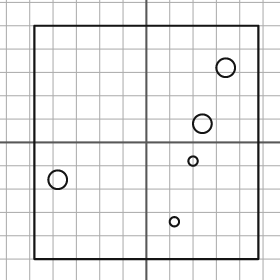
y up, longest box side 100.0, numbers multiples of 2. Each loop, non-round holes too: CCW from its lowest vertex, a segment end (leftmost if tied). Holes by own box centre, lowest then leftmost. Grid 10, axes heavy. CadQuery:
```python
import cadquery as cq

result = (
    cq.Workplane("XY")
    .moveTo(-48.0, -50.0)
    .lineTo(48.0, -50.0)
    .lineTo(48.0, 50.0)
    .lineTo(-48.0, 50.0)
    .close()
    .moveTo(12.0, -34.0)
    .circle(2.0)
    .moveTo(-38.0, -16.0)
    .circle(4.0)
    .moveTo(20.0, -8.0)
    .circle(2.0)
    .moveTo(24.0, 8.0)
    .circle(4.0)
    .moveTo(34.0, 32.0)
    .circle(4.0)
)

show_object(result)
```